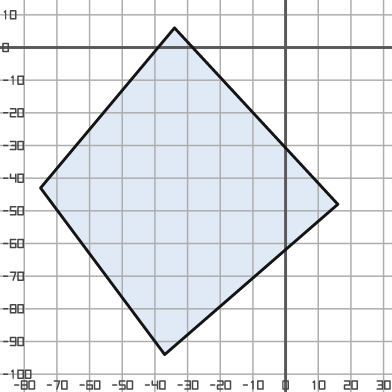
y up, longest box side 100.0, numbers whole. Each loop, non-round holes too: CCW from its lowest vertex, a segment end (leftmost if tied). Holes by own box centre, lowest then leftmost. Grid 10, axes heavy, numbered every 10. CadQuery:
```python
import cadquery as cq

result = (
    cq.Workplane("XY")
    .moveTo(-37.0, -94.0)
    .lineTo(16.0, -48.0)
    .lineTo(-34.0, 6.0)
    .lineTo(-75.0, -43.0)
    .close()
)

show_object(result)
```